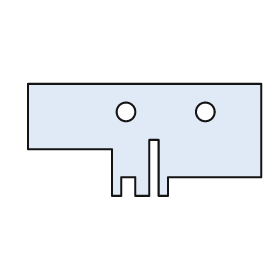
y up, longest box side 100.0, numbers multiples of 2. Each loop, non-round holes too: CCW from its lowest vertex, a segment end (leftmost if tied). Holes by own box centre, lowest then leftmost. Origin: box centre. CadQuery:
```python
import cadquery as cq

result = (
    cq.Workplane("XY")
    .moveTo(-14.0, -24.0)
    .lineTo(-10.0, -24.0)
    .lineTo(-10.0, -16.0)
    .lineTo(-4.0, -16.0)
    .lineTo(-4.0, -24.0)
    .lineTo(2.0, -24.0)
    .lineTo(2.0, 0.0)
    .lineTo(6.0, 0.0)
    .lineTo(6.0, -24.0)
    .lineTo(10.0, -24.0)
    .lineTo(10.0, -16.0)
    .lineTo(50.0, -16.0)
    .lineTo(50.0, 24.0)
    .lineTo(-50.0, 24.0)
    .lineTo(-50.0, -4.0)
    .lineTo(-14.0, -4.0)
    .close()
    .moveTo(-8.0, 12.0)
    .circle(4.0)
    .moveTo(26.0, 12.0)
    .circle(4.0)
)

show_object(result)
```